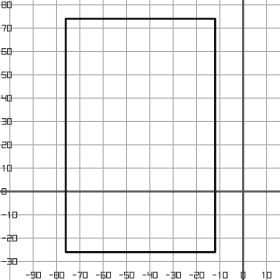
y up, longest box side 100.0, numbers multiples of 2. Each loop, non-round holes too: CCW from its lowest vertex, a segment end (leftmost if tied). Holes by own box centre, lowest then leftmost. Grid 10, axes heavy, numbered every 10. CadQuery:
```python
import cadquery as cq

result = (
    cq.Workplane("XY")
    .moveTo(-76.0, -26.0)
    .lineTo(-12.0, -26.0)
    .lineTo(-12.0, 74.0)
    .lineTo(-76.0, 74.0)
    .close()
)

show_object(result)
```